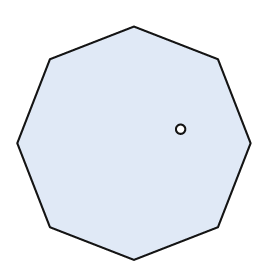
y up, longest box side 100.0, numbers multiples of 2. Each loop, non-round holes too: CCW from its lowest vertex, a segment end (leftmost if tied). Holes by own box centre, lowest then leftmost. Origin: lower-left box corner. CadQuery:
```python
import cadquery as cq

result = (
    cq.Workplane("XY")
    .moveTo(50.0, 0.0)
    .lineTo(86.0, 14.0)
    .lineTo(100.0, 50.0)
    .lineTo(86.0, 86.0)
    .lineTo(50.0, 100.0)
    .lineTo(14.0, 86.0)
    .lineTo(0.0, 50.0)
    .lineTo(14.0, 14.0)
    .close()
    .moveTo(70.0, 56.0)
    .circle(2.0)
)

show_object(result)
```